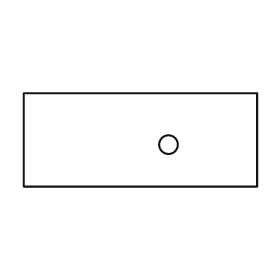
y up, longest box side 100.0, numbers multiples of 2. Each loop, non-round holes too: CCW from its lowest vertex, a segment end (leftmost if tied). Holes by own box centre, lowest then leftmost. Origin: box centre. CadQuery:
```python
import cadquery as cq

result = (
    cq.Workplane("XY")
    .moveTo(-50.0, -20.0)
    .lineTo(50.0, -20.0)
    .lineTo(50.0, 20.0)
    .lineTo(-50.0, 20.0)
    .close()
    .moveTo(12.0, -2.0)
    .circle(4.0)
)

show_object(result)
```